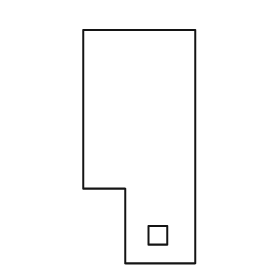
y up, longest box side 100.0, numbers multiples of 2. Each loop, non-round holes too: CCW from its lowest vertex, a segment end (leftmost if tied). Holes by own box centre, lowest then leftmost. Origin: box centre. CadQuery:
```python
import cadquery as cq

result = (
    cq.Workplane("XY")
    .moveTo(-6.0, -50.0)
    .lineTo(24.0, -50.0)
    .lineTo(24.0, 50.0)
    .lineTo(-24.0, 50.0)
    .lineTo(-24.0, -18.0)
    .lineTo(-6.0, -18.0)
    .close()
    .moveTo(4.0, -42.0)
    .lineTo(12.0, -42.0)
    .lineTo(12.0, -34.0)
    .lineTo(4.0, -34.0)
    .close()
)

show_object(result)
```